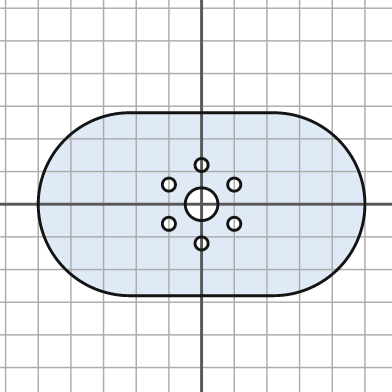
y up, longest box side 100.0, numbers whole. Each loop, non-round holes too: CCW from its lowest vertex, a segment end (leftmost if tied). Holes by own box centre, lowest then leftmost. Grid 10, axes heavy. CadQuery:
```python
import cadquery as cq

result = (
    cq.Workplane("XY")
    .moveTo(-22.0, -28.0)
    .lineTo(22.0, -28.0)
    .threePointArc((50.0, 0.0), (22.0, 28.0))
    .lineTo(-22.0, 28.0)
    .threePointArc((-50.0, 0.0), (-22.0, -28.0))
    .close()
    .moveTo(0.0, -12.0)
    .circle(2.0)
    .moveTo(-10.0, -6.0)
    .circle(2.0)
    .moveTo(10.0, -6.0)
    .circle(2.0)
    .moveTo(0.0, 0.0)
    .circle(5.0)
    .moveTo(-10.0, 6.0)
    .circle(2.0)
    .moveTo(10.0, 6.0)
    .circle(2.0)
    .moveTo(0.0, 12.0)
    .circle(2.0)
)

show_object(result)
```